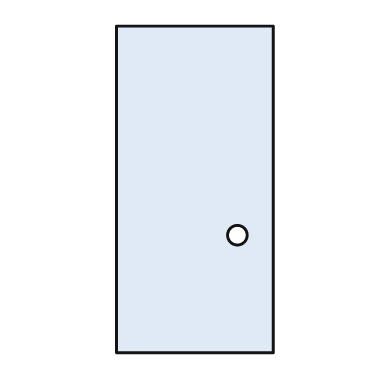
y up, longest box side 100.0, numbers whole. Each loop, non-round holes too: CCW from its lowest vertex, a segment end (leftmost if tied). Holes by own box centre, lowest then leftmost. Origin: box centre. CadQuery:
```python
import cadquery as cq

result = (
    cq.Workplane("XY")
    .moveTo(-24.0, -50.0)
    .lineTo(24.0, -50.0)
    .lineTo(24.0, 50.0)
    .lineTo(-24.0, 50.0)
    .close()
    .moveTo(13.0, -14.0)
    .circle(3.0)
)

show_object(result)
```